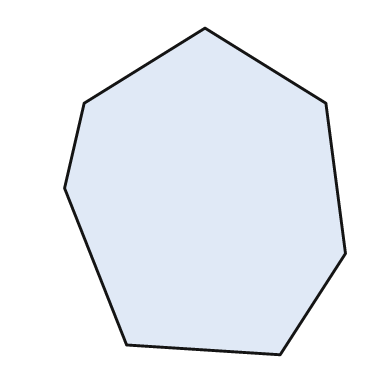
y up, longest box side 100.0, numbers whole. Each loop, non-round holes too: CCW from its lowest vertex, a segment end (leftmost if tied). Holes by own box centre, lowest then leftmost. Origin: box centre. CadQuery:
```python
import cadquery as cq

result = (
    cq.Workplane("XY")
    .moveTo(23.0, -50.0)
    .lineTo(43.0, -19.0)
    .lineTo(37.0, 27.0)
    .lineTo(0.0, 50.0)
    .lineTo(-37.0, 27.0)
    .lineTo(-43.0, 1.0)
    .lineTo(-24.0, -47.0)
    .close()
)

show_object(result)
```